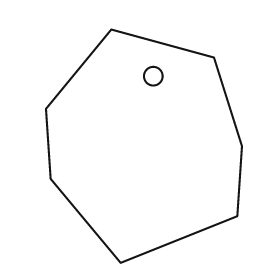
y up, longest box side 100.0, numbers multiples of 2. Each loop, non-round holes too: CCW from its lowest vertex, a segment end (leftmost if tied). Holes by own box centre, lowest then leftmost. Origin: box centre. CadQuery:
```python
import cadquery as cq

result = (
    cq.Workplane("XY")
    .moveTo(-10.0, -50.0)
    .lineTo(40.0, -30.0)
    .lineTo(42.0, 0.0)
    .lineTo(30.0, 38.0)
    .lineTo(-14.0, 50.0)
    .lineTo(-42.0, 16.0)
    .lineTo(-40.0, -14.0)
    .close()
    .moveTo(4.0, 30.0)
    .circle(4.0)
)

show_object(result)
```